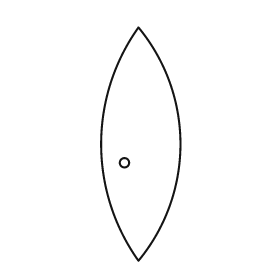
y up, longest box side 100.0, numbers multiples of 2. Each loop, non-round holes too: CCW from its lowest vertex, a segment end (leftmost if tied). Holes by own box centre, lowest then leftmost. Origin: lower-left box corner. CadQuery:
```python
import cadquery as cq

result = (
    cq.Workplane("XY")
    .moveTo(16.0, 0.0)
    .threePointArc((34.0, 50.0), (16.0, 100.0))
    .threePointArc((0.0, 50.0), (16.0, 0.0))
    .close()
    .moveTo(10.0, 42.0)
    .circle(2.0)
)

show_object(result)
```